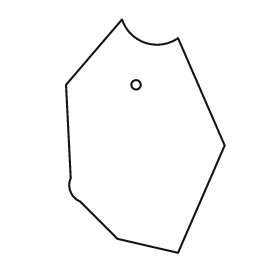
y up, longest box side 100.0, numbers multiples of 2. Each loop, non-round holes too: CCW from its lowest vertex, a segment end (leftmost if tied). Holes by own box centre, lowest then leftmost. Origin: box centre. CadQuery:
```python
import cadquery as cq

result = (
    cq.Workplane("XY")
    .moveTo(14.0, -50.0)
    .lineTo(34.0, -4.0)
    .lineTo(14.0, 42.0)
    .threePointArc((0.0, 40.0), (-10.0, 50.0))
    .lineTo(-34.0, 22.0)
    .lineTo(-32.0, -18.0)
    .threePointArc((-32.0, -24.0), (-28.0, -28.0))
    .lineTo(-12.0, -44.0)
    .close()
    .moveTo(-4.0, 22.0)
    .circle(2.0)
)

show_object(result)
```